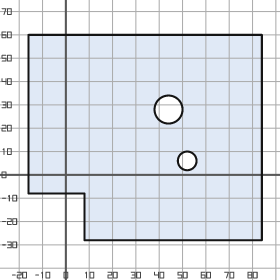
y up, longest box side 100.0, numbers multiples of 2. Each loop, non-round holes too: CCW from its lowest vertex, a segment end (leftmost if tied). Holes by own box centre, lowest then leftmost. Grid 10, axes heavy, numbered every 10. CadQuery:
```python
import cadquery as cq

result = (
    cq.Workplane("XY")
    .moveTo(8.0, -28.0)
    .lineTo(84.0, -28.0)
    .lineTo(84.0, 60.0)
    .lineTo(-16.0, 60.0)
    .lineTo(-16.0, -8.0)
    .lineTo(8.0, -8.0)
    .close()
    .moveTo(52.0, 6.0)
    .circle(4.0)
    .moveTo(44.0, 28.0)
    .circle(6.0)
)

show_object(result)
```